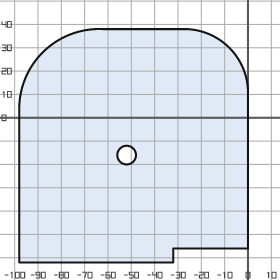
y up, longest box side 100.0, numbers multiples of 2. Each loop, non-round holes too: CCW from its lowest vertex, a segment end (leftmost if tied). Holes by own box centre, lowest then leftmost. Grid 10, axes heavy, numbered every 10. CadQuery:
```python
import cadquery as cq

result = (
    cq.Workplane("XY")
    .moveTo(-98.0, -62.0)
    .lineTo(-32.0, -62.0)
    .lineTo(-32.0, -56.0)
    .lineTo(0.0, -56.0)
    .lineTo(0.0, 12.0)
    .threePointArc((-8.0, 30.0), (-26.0, 38.0))
    .lineTo(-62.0, 38.0)
    .threePointArc((-88.0, 28.0), (-98.0, 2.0))
    .close()
    .moveTo(-52.0, -16.0)
    .circle(4.0)
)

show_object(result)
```